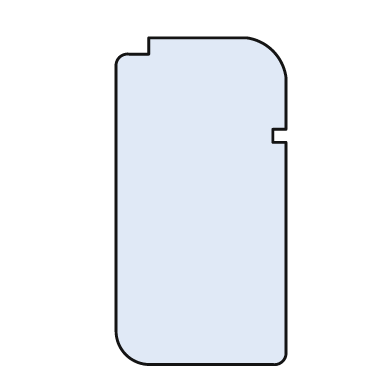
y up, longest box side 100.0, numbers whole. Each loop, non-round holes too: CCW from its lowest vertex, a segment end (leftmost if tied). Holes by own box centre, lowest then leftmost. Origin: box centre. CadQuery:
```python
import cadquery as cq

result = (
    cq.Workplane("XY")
    .moveTo(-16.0, -50.0)
    .lineTo(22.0, -50.0)
    .threePointArc((25.0, -49.0), (26.0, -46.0))
    .lineTo(26.0, 18.0)
    .lineTo(22.0, 18.0)
    .lineTo(22.0, 22.0)
    .lineTo(26.0, 22.0)
    .lineTo(26.0, 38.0)
    .threePointArc((22.0, 46.0), (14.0, 50.0))
    .lineTo(-16.0, 50.0)
    .lineTo(-16.0, 45.0)
    .lineTo(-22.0, 45.0)
    .threePointArc((-25.0, 44.0), (-26.0, 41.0))
    .lineTo(-26.0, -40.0)
    .threePointArc((-23.0, -47.0), (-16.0, -50.0))
    .close()
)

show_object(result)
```